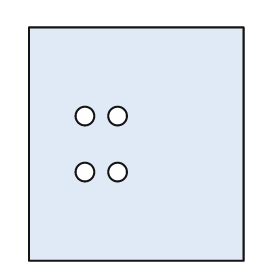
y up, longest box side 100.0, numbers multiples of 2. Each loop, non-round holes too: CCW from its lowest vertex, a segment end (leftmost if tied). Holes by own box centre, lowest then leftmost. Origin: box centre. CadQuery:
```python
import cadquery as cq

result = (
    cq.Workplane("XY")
    .moveTo(-46.0, -50.0)
    .lineTo(46.0, -50.0)
    .lineTo(46.0, 50.0)
    .lineTo(-46.0, 50.0)
    .close()
    .moveTo(-22.0, -12.0)
    .circle(4.0)
    .moveTo(-8.0, -12.0)
    .circle(4.0)
    .moveTo(-22.0, 12.0)
    .circle(4.0)
    .moveTo(-8.0, 12.0)
    .circle(4.0)
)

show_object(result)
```